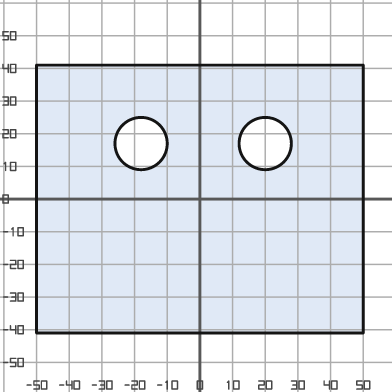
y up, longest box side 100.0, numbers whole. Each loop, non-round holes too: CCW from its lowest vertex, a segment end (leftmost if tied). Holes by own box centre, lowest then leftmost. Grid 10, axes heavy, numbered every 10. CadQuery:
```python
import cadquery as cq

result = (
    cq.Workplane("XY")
    .moveTo(-50.0, -41.0)
    .lineTo(50.0, -41.0)
    .lineTo(50.0, 41.0)
    .lineTo(-50.0, 41.0)
    .close()
    .moveTo(-18.0, 17.0)
    .circle(8.0)
    .moveTo(20.0, 17.0)
    .circle(8.0)
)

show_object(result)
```